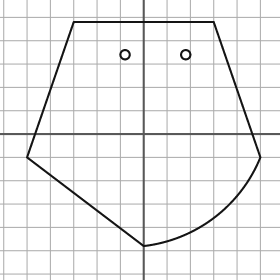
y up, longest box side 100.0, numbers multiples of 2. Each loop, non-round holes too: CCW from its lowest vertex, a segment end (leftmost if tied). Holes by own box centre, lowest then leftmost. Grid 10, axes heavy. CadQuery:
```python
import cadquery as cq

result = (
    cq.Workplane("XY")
    .moveTo(0.0, -48.0)
    .threePointArc((30.0, -36.0), (50.0, -10.0))
    .lineTo(30.0, 48.0)
    .lineTo(-30.0, 48.0)
    .lineTo(-50.0, -10.0)
    .close()
    .moveTo(-8.0, 34.0)
    .circle(2.0)
    .moveTo(18.0, 34.0)
    .circle(2.0)
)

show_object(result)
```